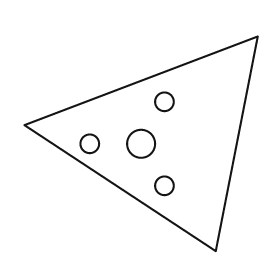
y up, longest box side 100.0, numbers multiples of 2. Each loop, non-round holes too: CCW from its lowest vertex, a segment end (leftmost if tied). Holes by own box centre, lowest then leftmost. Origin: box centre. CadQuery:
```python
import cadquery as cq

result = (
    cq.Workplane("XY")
    .moveTo(32.0, -46.0)
    .lineTo(50.0, 46.0)
    .lineTo(-50.0, 8.0)
    .close()
    .moveTo(10.0, -18.0)
    .circle(4.0)
    .moveTo(-22.0, 0.0)
    .circle(4.0)
    .moveTo(0.0, 0.0)
    .circle(6.0)
    .moveTo(10.0, 18.0)
    .circle(4.0)
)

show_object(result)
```